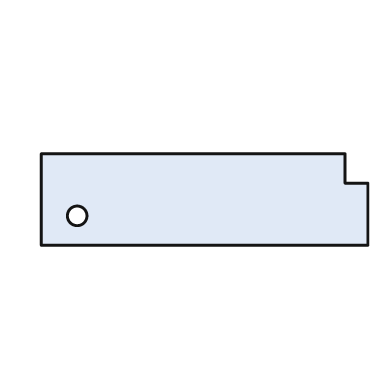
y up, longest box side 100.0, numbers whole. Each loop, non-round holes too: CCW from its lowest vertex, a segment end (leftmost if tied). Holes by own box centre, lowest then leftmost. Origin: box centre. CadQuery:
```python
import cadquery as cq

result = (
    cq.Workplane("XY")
    .moveTo(-50.0, -14.0)
    .lineTo(50.0, -14.0)
    .lineTo(50.0, 5.0)
    .lineTo(43.0, 5.0)
    .lineTo(43.0, 14.0)
    .lineTo(-50.0, 14.0)
    .close()
    .moveTo(-39.0, -5.0)
    .circle(3.0)
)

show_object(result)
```